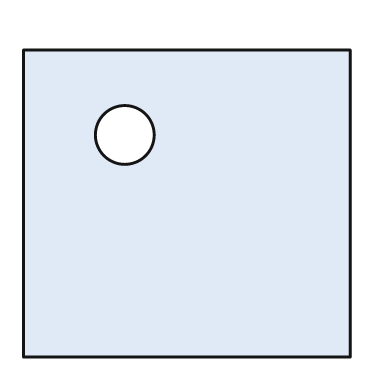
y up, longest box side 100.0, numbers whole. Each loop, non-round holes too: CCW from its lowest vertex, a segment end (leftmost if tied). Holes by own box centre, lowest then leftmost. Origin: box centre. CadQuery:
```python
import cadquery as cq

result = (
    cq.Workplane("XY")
    .moveTo(-50.0, -47.0)
    .lineTo(50.0, -47.0)
    .lineTo(50.0, 47.0)
    .lineTo(-50.0, 47.0)
    .close()
    .moveTo(-19.0, 21.0)
    .circle(9.0)
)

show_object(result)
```